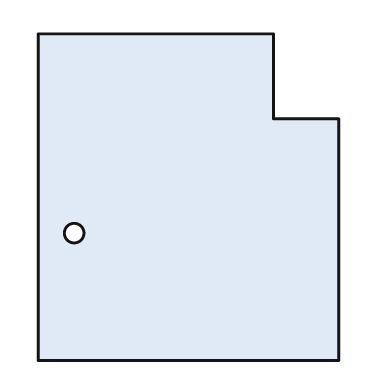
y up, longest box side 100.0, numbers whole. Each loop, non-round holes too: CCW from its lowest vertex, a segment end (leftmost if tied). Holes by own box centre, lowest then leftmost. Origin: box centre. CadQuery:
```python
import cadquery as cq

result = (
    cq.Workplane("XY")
    .moveTo(-46.0, -50.0)
    .lineTo(46.0, -50.0)
    .lineTo(46.0, 24.0)
    .lineTo(26.0, 24.0)
    .lineTo(26.0, 50.0)
    .lineTo(-46.0, 50.0)
    .close()
    .moveTo(-35.0, -11.0)
    .circle(3.0)
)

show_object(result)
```